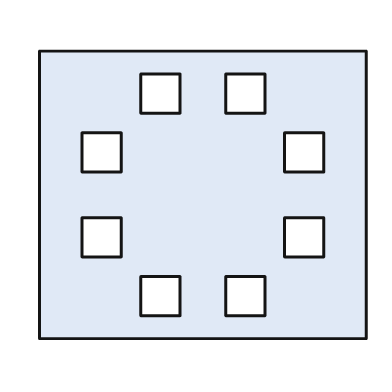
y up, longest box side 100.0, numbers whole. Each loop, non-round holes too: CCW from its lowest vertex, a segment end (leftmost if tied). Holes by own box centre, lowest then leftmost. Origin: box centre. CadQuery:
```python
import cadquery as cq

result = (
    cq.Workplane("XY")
    .moveTo(-50.0, -44.0)
    .lineTo(50.0, -44.0)
    .lineTo(50.0, 44.0)
    .lineTo(-50.0, 44.0)
    .close()
    .moveTo(-19.0, -37.0)
    .lineTo(-7.0, -37.0)
    .lineTo(-7.0, -25.0)
    .lineTo(-19.0, -25.0)
    .close()
    .moveTo(7.0, -37.0)
    .lineTo(19.0, -37.0)
    .lineTo(19.0, -25.0)
    .lineTo(7.0, -25.0)
    .close()
    .moveTo(-37.0, -19.0)
    .lineTo(-25.0, -19.0)
    .lineTo(-25.0, -7.0)
    .lineTo(-37.0, -7.0)
    .close()
    .moveTo(25.0, -19.0)
    .lineTo(37.0, -19.0)
    .lineTo(37.0, -7.0)
    .lineTo(25.0, -7.0)
    .close()
    .moveTo(-37.0, 7.0)
    .lineTo(-25.0, 7.0)
    .lineTo(-25.0, 19.0)
    .lineTo(-37.0, 19.0)
    .close()
    .moveTo(25.0, 7.0)
    .lineTo(37.0, 7.0)
    .lineTo(37.0, 19.0)
    .lineTo(25.0, 19.0)
    .close()
    .moveTo(-19.0, 25.0)
    .lineTo(-7.0, 25.0)
    .lineTo(-7.0, 37.0)
    .lineTo(-19.0, 37.0)
    .close()
    .moveTo(7.0, 25.0)
    .lineTo(19.0, 25.0)
    .lineTo(19.0, 37.0)
    .lineTo(7.0, 37.0)
    .close()
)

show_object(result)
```